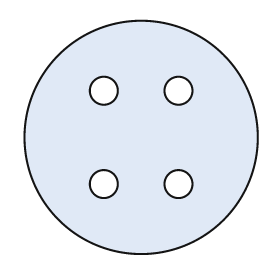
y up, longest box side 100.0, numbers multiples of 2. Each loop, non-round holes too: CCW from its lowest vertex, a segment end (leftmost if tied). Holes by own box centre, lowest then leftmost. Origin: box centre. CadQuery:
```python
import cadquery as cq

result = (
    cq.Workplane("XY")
    .moveTo(0.0, 0.0)
    .circle(50.0)
    .moveTo(-16.0, -20.0)
    .circle(6.0)
    .moveTo(16.0, -20.0)
    .circle(6.0)
    .moveTo(-16.0, 20.0)
    .circle(6.0)
    .moveTo(16.0, 20.0)
    .circle(6.0)
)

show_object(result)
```